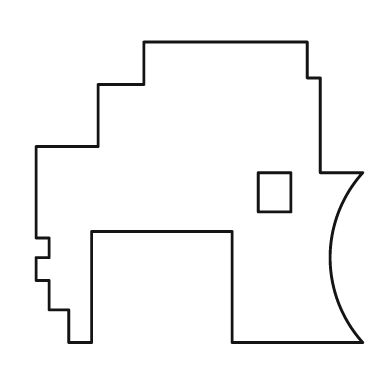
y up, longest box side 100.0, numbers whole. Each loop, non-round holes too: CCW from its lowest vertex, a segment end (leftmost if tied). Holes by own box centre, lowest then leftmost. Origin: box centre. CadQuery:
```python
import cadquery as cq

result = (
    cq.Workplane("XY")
    .moveTo(-40.0, -46.0)
    .lineTo(-33.0, -46.0)
    .lineTo(-33.0, -12.0)
    .lineTo(10.0, -12.0)
    .lineTo(10.0, -46.0)
    .lineTo(50.0, -46.0)
    .threePointArc((40.0, -20.0), (50.0, 6.0))
    .lineTo(37.0, 6.0)
    .lineTo(37.0, 35.0)
    .lineTo(33.0, 35.0)
    .lineTo(33.0, 46.0)
    .lineTo(-17.0, 46.0)
    .lineTo(-17.0, 33.0)
    .lineTo(-31.0, 33.0)
    .lineTo(-31.0, 14.0)
    .lineTo(-50.0, 14.0)
    .lineTo(-50.0, -14.0)
    .lineTo(-46.0, -14.0)
    .lineTo(-46.0, -20.0)
    .lineTo(-50.0, -20.0)
    .lineTo(-50.0, -27.0)
    .lineTo(-46.0, -27.0)
    .lineTo(-46.0, -36.0)
    .lineTo(-40.0, -36.0)
    .close()
    .moveTo(18.0, -6.0)
    .lineTo(28.0, -6.0)
    .lineTo(28.0, 6.0)
    .lineTo(18.0, 6.0)
    .close()
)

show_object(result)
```